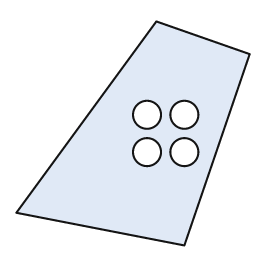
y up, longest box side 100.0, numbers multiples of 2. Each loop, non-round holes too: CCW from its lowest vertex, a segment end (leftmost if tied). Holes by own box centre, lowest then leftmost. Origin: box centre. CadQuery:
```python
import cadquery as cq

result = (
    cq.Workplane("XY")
    .moveTo(22.0, -48.0)
    .lineTo(50.0, 34.0)
    .lineTo(10.0, 48.0)
    .lineTo(-50.0, -34.0)
    .close()
    .moveTo(6.0, -8.0)
    .circle(6.0)
    .moveTo(22.0, -8.0)
    .circle(6.0)
    .moveTo(6.0, 8.0)
    .circle(6.0)
    .moveTo(22.0, 8.0)
    .circle(6.0)
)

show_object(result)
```